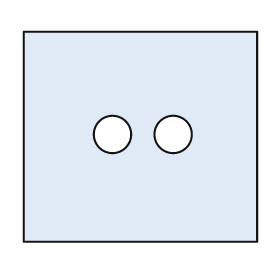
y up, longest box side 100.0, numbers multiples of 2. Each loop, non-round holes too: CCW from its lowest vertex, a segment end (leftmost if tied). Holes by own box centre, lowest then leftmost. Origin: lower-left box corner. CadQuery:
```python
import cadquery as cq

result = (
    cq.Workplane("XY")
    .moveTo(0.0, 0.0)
    .lineTo(100.0, 0.0)
    .lineTo(100.0, 90.0)
    .lineTo(0.0, 90.0)
    .close()
    .moveTo(38.0, 46.0)
    .circle(8.0)
    .moveTo(64.0, 46.0)
    .circle(8.0)
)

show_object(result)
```